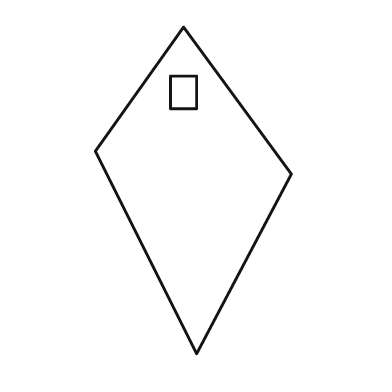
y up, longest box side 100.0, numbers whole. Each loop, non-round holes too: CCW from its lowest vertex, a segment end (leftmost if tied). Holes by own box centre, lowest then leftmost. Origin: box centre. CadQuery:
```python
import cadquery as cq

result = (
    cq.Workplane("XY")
    .moveTo(1.0, -50.0)
    .lineTo(30.0, 5.0)
    .lineTo(-3.0, 50.0)
    .lineTo(-30.0, 12.0)
    .close()
    .moveTo(-7.0, 25.0)
    .lineTo(1.0, 25.0)
    .lineTo(1.0, 35.0)
    .lineTo(-7.0, 35.0)
    .close()
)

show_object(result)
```